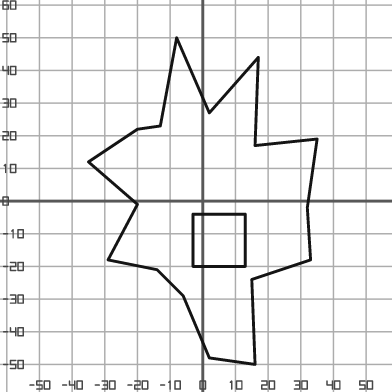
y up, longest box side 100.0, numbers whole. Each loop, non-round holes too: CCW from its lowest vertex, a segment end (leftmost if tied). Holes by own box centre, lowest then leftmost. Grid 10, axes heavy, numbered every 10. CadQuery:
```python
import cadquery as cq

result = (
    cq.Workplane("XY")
    .moveTo(16.0, -50.0)
    .lineTo(15.0, -24.0)
    .lineTo(33.0, -18.0)
    .lineTo(32.0, -2.0)
    .lineTo(35.0, 19.0)
    .lineTo(16.0, 17.0)
    .lineTo(17.0, 44.0)
    .lineTo(2.0, 27.0)
    .lineTo(-8.0, 50.0)
    .lineTo(-13.0, 23.0)
    .lineTo(-20.0, 22.0)
    .lineTo(-35.0, 12.0)
    .lineTo(-20.0, -1.0)
    .lineTo(-29.0, -18.0)
    .lineTo(-14.0, -21.0)
    .lineTo(-6.0, -29.0)
    .lineTo(2.0, -48.0)
    .close()
    .moveTo(-3.0, -20.0)
    .lineTo(13.0, -20.0)
    .lineTo(13.0, -4.0)
    .lineTo(-3.0, -4.0)
    .close()
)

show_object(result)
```